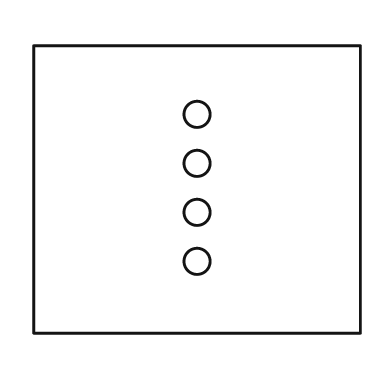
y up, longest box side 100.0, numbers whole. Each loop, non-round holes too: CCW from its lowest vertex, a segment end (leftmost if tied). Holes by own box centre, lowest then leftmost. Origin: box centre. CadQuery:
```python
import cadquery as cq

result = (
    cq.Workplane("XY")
    .moveTo(-50.0, -44.0)
    .lineTo(50.0, -44.0)
    .lineTo(50.0, 44.0)
    .lineTo(-50.0, 44.0)
    .close()
    .moveTo(0.0, -22.0)
    .circle(4.0)
    .moveTo(0.0, -7.0)
    .circle(4.0)
    .moveTo(0.0, 8.0)
    .circle(4.0)
    .moveTo(0.0, 23.0)
    .circle(4.0)
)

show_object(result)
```